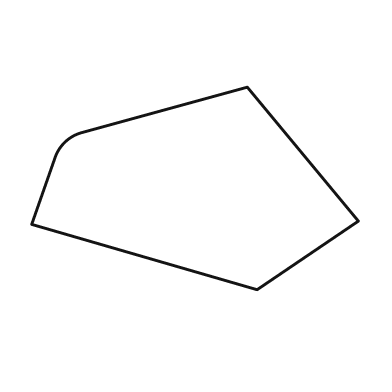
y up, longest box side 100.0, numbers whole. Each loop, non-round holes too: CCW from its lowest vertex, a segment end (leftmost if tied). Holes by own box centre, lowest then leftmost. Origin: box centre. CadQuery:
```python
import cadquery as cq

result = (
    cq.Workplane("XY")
    .moveTo(19.0, -31.0)
    .lineTo(50.0, -10.0)
    .lineTo(16.0, 31.0)
    .lineTo(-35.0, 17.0)
    .threePointArc((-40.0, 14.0), (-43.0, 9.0))
    .lineTo(-50.0, -11.0)
    .close()
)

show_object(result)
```